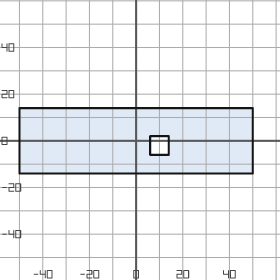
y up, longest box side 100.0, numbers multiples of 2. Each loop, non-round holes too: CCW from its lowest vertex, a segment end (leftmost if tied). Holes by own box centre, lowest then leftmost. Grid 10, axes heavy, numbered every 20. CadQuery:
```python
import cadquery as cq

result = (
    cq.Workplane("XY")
    .moveTo(-50.0, -14.0)
    .lineTo(50.0, -14.0)
    .lineTo(50.0, 14.0)
    .lineTo(-50.0, 14.0)
    .close()
    .moveTo(6.0, -6.0)
    .lineTo(14.0, -6.0)
    .lineTo(14.0, 2.0)
    .lineTo(6.0, 2.0)
    .close()
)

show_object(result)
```